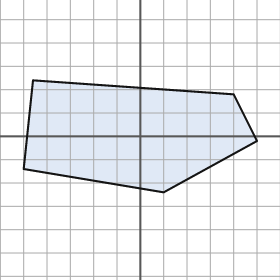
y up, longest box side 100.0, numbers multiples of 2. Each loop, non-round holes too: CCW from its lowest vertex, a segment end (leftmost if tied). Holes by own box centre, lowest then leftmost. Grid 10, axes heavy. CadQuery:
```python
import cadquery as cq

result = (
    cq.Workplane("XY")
    .moveTo(10.0, -24.0)
    .lineTo(50.0, -2.0)
    .lineTo(40.0, 18.0)
    .lineTo(-46.0, 24.0)
    .lineTo(-50.0, -14.0)
    .close()
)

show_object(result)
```